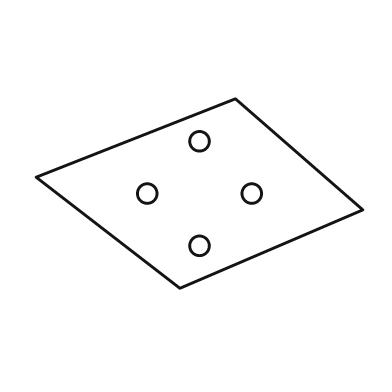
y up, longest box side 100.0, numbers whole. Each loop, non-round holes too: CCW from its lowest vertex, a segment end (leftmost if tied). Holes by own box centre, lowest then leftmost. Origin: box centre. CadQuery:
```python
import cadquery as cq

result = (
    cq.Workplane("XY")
    .moveTo(-6.0, -29.0)
    .lineTo(50.0, -5.0)
    .lineTo(11.0, 29.0)
    .lineTo(-50.0, 5.0)
    .close()
    .moveTo(0.0, -16.0)
    .circle(3.0)
    .moveTo(-16.0, 0.0)
    .circle(3.0)
    .moveTo(16.0, 0.0)
    .circle(3.0)
    .moveTo(0.0, 16.0)
    .circle(3.0)
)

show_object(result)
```